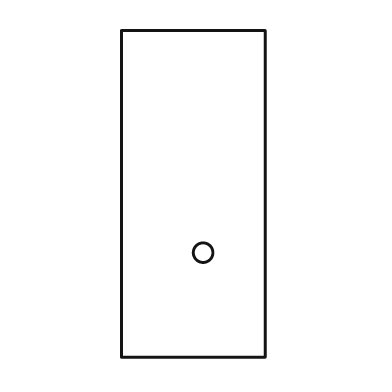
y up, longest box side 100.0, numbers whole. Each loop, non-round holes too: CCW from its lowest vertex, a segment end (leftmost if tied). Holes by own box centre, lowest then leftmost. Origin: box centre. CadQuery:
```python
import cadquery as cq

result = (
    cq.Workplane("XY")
    .moveTo(-22.0, -50.0)
    .lineTo(22.0, -50.0)
    .lineTo(22.0, 50.0)
    .lineTo(-22.0, 50.0)
    .close()
    .moveTo(3.0, -18.0)
    .circle(3.0)
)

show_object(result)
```